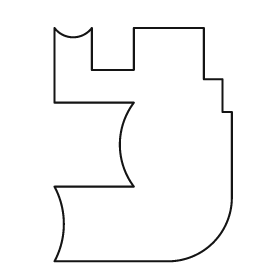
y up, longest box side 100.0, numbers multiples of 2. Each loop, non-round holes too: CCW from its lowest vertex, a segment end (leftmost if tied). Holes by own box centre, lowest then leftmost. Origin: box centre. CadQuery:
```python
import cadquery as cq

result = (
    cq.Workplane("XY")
    .moveTo(-38.0, -50.0)
    .lineTo(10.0, -50.0)
    .threePointArc((30.0, -42.0), (38.0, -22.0))
    .lineTo(38.0, 14.0)
    .lineTo(34.0, 14.0)
    .lineTo(34.0, 28.0)
    .lineTo(26.0, 28.0)
    .lineTo(26.0, 50.0)
    .lineTo(-4.0, 50.0)
    .lineTo(-4.0, 32.0)
    .lineTo(-22.0, 32.0)
    .lineTo(-22.0, 50.0)
    .threePointArc((-30.0, 46.0), (-38.0, 50.0))
    .lineTo(-38.0, 18.0)
    .lineTo(-4.0, 18.0)
    .threePointArc((-10.0, 0.0), (-4.0, -18.0))
    .lineTo(-38.0, -18.0)
    .threePointArc((-34.0, -34.0), (-38.0, -50.0))
    .close()
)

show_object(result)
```